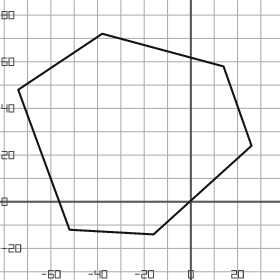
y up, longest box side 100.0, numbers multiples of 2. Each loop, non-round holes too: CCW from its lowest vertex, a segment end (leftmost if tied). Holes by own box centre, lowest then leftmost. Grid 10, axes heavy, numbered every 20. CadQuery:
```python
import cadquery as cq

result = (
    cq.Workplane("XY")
    .moveTo(-16.0, -14.0)
    .lineTo(26.0, 24.0)
    .lineTo(14.0, 58.0)
    .lineTo(-38.0, 72.0)
    .lineTo(-74.0, 48.0)
    .lineTo(-52.0, -12.0)
    .close()
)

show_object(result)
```